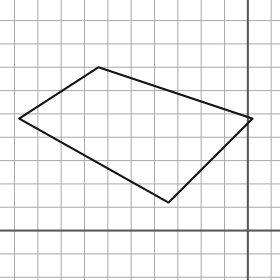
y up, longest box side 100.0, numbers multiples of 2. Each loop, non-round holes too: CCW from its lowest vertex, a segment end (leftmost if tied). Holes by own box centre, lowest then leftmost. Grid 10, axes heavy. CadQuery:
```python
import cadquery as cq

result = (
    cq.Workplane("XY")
    .moveTo(-34.0, 12.0)
    .lineTo(2.0, 48.0)
    .lineTo(-64.0, 70.0)
    .lineTo(-98.0, 48.0)
    .close()
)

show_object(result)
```